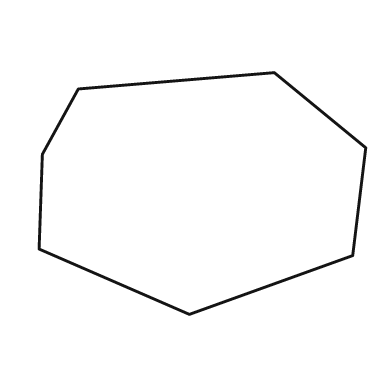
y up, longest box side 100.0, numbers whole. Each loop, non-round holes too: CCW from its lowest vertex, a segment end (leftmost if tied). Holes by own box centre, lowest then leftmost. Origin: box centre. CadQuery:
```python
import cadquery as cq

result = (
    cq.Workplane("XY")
    .moveTo(-4.0, -37.0)
    .lineTo(46.0, -19.0)
    .lineTo(50.0, 14.0)
    .lineTo(22.0, 37.0)
    .lineTo(-38.0, 32.0)
    .lineTo(-49.0, 12.0)
    .lineTo(-50.0, -17.0)
    .close()
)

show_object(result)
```